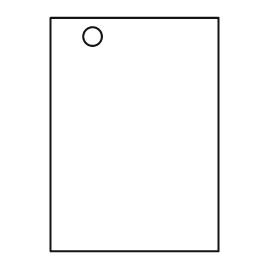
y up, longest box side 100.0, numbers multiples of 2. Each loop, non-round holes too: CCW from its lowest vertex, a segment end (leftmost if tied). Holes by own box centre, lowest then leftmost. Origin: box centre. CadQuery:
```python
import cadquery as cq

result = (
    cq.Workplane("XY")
    .moveTo(-36.0, -50.0)
    .lineTo(36.0, -50.0)
    .lineTo(36.0, 50.0)
    .lineTo(-36.0, 50.0)
    .close()
    .moveTo(-18.0, 42.0)
    .circle(4.0)
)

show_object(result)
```